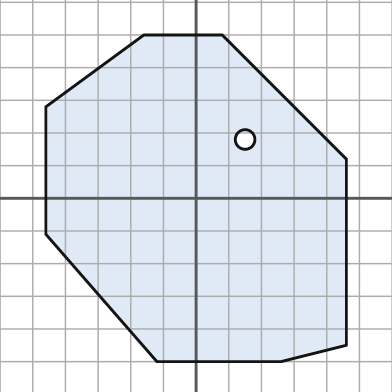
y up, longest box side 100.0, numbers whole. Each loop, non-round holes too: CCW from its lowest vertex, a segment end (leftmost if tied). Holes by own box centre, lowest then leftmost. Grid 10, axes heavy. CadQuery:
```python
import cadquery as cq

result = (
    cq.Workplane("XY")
    .moveTo(-12.0, -50.0)
    .lineTo(26.0, -50.0)
    .lineTo(46.0, -45.0)
    .lineTo(46.0, 12.0)
    .lineTo(8.0, 50.0)
    .lineTo(-16.0, 50.0)
    .lineTo(-46.0, 28.0)
    .lineTo(-46.0, -11.0)
    .close()
    .moveTo(15.0, 18.0)
    .circle(3.0)
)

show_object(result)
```